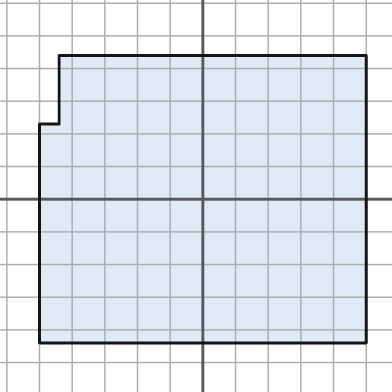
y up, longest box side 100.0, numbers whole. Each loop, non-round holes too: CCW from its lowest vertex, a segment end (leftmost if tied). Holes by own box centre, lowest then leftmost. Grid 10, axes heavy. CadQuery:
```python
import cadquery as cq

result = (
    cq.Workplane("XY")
    .moveTo(-50.0, -44.0)
    .lineTo(50.0, -44.0)
    .lineTo(50.0, 44.0)
    .lineTo(-44.0, 44.0)
    .lineTo(-44.0, 23.0)
    .lineTo(-50.0, 23.0)
    .close()
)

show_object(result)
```